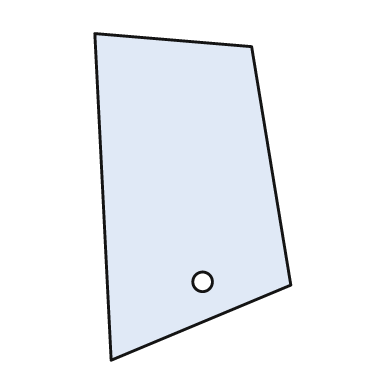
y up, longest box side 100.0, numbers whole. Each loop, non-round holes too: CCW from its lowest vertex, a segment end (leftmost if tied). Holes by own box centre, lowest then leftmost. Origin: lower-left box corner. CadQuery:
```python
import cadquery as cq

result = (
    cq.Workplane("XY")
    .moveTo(5.0, 0.0)
    .lineTo(60.0, 23.0)
    .lineTo(48.0, 96.0)
    .lineTo(0.0, 100.0)
    .close()
    .moveTo(33.0, 24.0)
    .circle(3.0)
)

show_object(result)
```